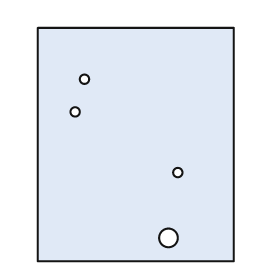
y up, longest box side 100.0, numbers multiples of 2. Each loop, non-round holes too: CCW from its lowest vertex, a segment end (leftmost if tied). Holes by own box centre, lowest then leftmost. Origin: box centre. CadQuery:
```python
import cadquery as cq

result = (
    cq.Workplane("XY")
    .moveTo(-42.0, -50.0)
    .lineTo(42.0, -50.0)
    .lineTo(42.0, 50.0)
    .lineTo(-42.0, 50.0)
    .close()
    .moveTo(14.0, -40.0)
    .circle(4.0)
    .moveTo(18.0, -12.0)
    .circle(2.0)
    .moveTo(-26.0, 14.0)
    .circle(2.0)
    .moveTo(-22.0, 28.0)
    .circle(2.0)
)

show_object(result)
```